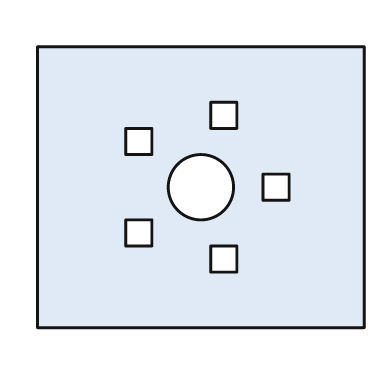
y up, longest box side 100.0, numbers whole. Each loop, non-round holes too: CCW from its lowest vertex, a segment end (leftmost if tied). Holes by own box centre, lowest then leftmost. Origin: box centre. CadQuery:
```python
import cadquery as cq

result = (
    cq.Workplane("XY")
    .moveTo(-50.0, -43.0)
    .lineTo(50.0, -43.0)
    .lineTo(50.0, 43.0)
    .lineTo(-50.0, 43.0)
    .close()
    .moveTo(3.0, -26.0)
    .lineTo(11.0, -26.0)
    .lineTo(11.0, -18.0)
    .lineTo(3.0, -18.0)
    .close()
    .moveTo(-23.0, -18.0)
    .lineTo(-15.0, -18.0)
    .lineTo(-15.0, -10.0)
    .lineTo(-23.0, -10.0)
    .close()
    .moveTo(0.0, 0.0)
    .circle(10.0)
    .moveTo(19.0, -4.0)
    .lineTo(27.0, -4.0)
    .lineTo(27.0, 4.0)
    .lineTo(19.0, 4.0)
    .close()
    .moveTo(-23.0, 10.0)
    .lineTo(-15.0, 10.0)
    .lineTo(-15.0, 18.0)
    .lineTo(-23.0, 18.0)
    .close()
    .moveTo(3.0, 18.0)
    .lineTo(11.0, 18.0)
    .lineTo(11.0, 26.0)
    .lineTo(3.0, 26.0)
    .close()
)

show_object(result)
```